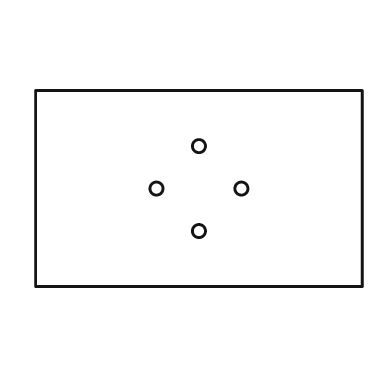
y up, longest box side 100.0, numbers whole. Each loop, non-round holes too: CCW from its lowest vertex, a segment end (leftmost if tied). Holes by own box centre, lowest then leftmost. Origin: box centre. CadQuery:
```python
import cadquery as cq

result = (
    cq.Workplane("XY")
    .moveTo(-50.0, -30.0)
    .lineTo(50.0, -30.0)
    .lineTo(50.0, 30.0)
    .lineTo(-50.0, 30.0)
    .close()
    .moveTo(0.0, -13.0)
    .circle(2.0)
    .moveTo(-13.0, 0.0)
    .circle(2.0)
    .moveTo(13.0, 0.0)
    .circle(2.0)
    .moveTo(0.0, 13.0)
    .circle(2.0)
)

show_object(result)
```